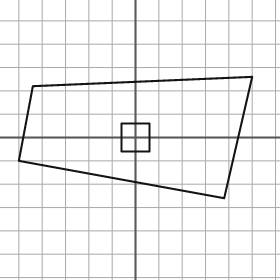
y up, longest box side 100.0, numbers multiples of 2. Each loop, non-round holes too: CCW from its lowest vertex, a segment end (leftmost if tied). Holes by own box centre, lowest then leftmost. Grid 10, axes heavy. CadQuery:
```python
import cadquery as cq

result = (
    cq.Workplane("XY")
    .moveTo(38.0, -26.0)
    .lineTo(50.0, 26.0)
    .lineTo(-44.0, 22.0)
    .lineTo(-50.0, -10.0)
    .close()
    .moveTo(-6.0, -6.0)
    .lineTo(6.0, -6.0)
    .lineTo(6.0, 6.0)
    .lineTo(-6.0, 6.0)
    .close()
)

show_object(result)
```